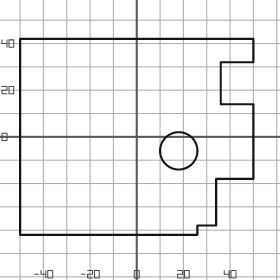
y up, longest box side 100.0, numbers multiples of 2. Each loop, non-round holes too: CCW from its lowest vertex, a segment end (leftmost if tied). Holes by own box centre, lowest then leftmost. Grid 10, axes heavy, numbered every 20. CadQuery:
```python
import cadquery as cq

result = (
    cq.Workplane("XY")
    .moveTo(-50.0, -42.0)
    .lineTo(26.0, -42.0)
    .lineTo(26.0, -38.0)
    .lineTo(34.0, -38.0)
    .lineTo(34.0, -18.0)
    .lineTo(50.0, -18.0)
    .lineTo(50.0, 14.0)
    .lineTo(36.0, 14.0)
    .lineTo(36.0, 32.0)
    .lineTo(50.0, 32.0)
    .lineTo(50.0, 42.0)
    .lineTo(-50.0, 42.0)
    .close()
    .moveTo(18.0, -6.0)
    .circle(8.0)
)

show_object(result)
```